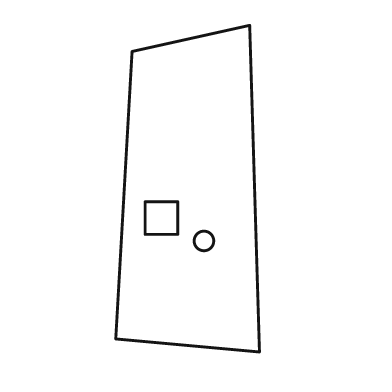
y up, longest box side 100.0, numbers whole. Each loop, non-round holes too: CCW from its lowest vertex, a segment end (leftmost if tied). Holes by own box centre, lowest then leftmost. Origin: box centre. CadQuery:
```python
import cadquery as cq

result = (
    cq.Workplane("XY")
    .moveTo(22.0, -50.0)
    .lineTo(19.0, 50.0)
    .lineTo(-17.0, 42.0)
    .lineTo(-22.0, -46.0)
    .close()
    .moveTo(5.0, -16.0)
    .circle(3.0)
    .moveTo(-13.0, -14.0)
    .lineTo(-3.0, -14.0)
    .lineTo(-3.0, -4.0)
    .lineTo(-13.0, -4.0)
    .close()
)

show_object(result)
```